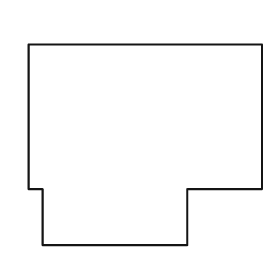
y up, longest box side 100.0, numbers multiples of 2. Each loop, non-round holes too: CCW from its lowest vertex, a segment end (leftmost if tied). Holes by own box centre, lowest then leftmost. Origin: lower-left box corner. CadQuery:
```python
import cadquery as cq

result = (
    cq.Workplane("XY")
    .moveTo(6.0, 0.0)
    .lineTo(68.0, 0.0)
    .lineTo(68.0, 24.0)
    .lineTo(100.0, 24.0)
    .lineTo(100.0, 86.0)
    .lineTo(0.0, 86.0)
    .lineTo(0.0, 24.0)
    .lineTo(6.0, 24.0)
    .close()
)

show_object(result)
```